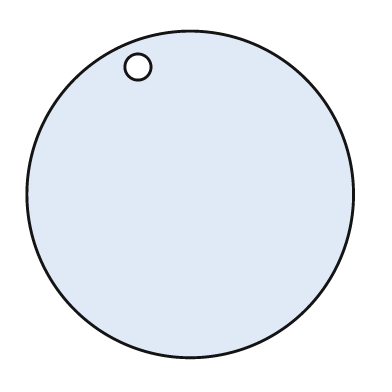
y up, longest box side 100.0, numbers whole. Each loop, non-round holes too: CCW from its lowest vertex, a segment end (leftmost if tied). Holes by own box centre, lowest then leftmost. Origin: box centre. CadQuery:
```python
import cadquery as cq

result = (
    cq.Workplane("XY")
    .moveTo(0.0, 0.0)
    .circle(50.0)
    .moveTo(-16.0, 39.0)
    .circle(4.0)
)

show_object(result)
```